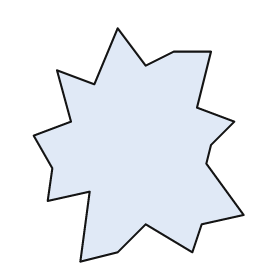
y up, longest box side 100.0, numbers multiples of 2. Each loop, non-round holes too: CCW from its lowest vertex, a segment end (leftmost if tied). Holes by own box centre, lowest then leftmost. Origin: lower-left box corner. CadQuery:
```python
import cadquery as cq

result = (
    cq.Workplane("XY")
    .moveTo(20.0, 0.0)
    .lineTo(36.0, 4.0)
    .lineTo(48.0, 16.0)
    .lineTo(68.0, 4.0)
    .lineTo(72.0, 16.0)
    .lineTo(90.0, 20.0)
    .lineTo(74.0, 42.0)
    .lineTo(76.0, 50.0)
    .lineTo(86.0, 60.0)
    .lineTo(70.0, 66.0)
    .lineTo(76.0, 90.0)
    .lineTo(60.0, 90.0)
    .lineTo(48.0, 84.0)
    .lineTo(36.0, 100.0)
    .lineTo(26.0, 76.0)
    .lineTo(10.0, 82.0)
    .lineTo(16.0, 60.0)
    .lineTo(0.0, 54.0)
    .lineTo(8.0, 40.0)
    .lineTo(6.0, 26.0)
    .lineTo(24.0, 30.0)
    .close()
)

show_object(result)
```